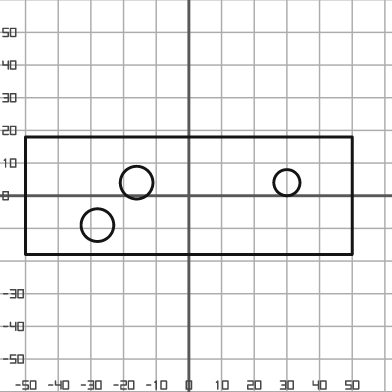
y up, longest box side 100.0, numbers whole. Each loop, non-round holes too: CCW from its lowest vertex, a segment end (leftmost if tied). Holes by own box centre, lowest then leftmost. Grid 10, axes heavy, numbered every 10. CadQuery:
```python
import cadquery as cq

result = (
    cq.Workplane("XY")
    .moveTo(-50.0, -18.0)
    .lineTo(50.0, -18.0)
    .lineTo(50.0, 18.0)
    .lineTo(-50.0, 18.0)
    .close()
    .moveTo(-28.0, -9.0)
    .circle(5.0)
    .moveTo(-16.0, 4.0)
    .circle(5.0)
    .moveTo(30.0, 4.0)
    .circle(4.0)
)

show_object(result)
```